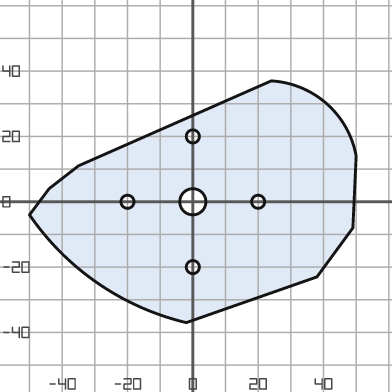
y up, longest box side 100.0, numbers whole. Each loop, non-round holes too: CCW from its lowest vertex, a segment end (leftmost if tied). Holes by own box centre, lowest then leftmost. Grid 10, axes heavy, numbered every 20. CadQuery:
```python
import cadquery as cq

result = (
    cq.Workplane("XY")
    .moveTo(-2.0, -37.0)
    .lineTo(38.0, -23.0)
    .lineTo(49.0, -8.0)
    .lineTo(50.0, 14.0)
    .threePointArc((41.0, 30.0), (24.0, 37.0))
    .lineTo(-35.0, 11.0)
    .lineTo(-44.0, 4.0)
    .lineTo(-50.0, -4.0)
    .threePointArc((-29.0, -25.0), (-2.0, -37.0))
    .close()
    .moveTo(0.0, -20.0)
    .circle(2.0)
    .moveTo(-20.0, 0.0)
    .circle(2.0)
    .moveTo(0.0, 0.0)
    .circle(4.0)
    .moveTo(20.0, 0.0)
    .circle(2.0)
    .moveTo(0.0, 20.0)
    .circle(2.0)
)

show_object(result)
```